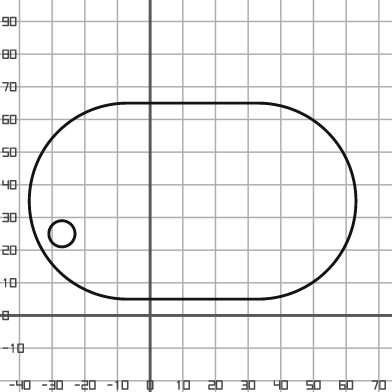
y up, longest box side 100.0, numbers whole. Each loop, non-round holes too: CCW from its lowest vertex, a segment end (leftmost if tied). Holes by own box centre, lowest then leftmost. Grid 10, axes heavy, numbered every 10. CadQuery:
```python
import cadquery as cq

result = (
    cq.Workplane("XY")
    .moveTo(-7.0, 5.0)
    .lineTo(33.0, 5.0)
    .threePointArc((63.0, 35.0), (33.0, 65.0))
    .lineTo(-7.0, 65.0)
    .threePointArc((-37.0, 35.0), (-7.0, 5.0))
    .close()
    .moveTo(-27.0, 25.0)
    .circle(4.0)
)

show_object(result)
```